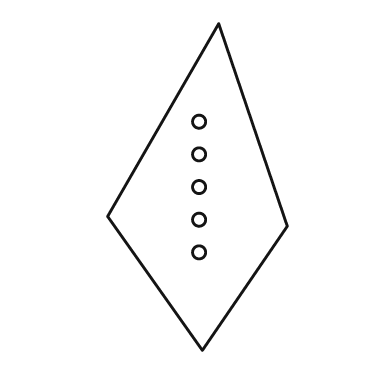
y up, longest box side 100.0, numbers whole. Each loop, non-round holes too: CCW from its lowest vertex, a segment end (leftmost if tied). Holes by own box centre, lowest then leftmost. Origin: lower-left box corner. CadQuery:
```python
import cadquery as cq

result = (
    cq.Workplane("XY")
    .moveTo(29.0, 0.0)
    .lineTo(55.0, 38.0)
    .lineTo(34.0, 100.0)
    .lineTo(0.0, 41.0)
    .close()
    .moveTo(28.0, 30.0)
    .circle(2.0)
    .moveTo(28.0, 40.0)
    .circle(2.0)
    .moveTo(28.0, 50.0)
    .circle(2.0)
    .moveTo(28.0, 60.0)
    .circle(2.0)
    .moveTo(28.0, 70.0)
    .circle(2.0)
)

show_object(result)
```